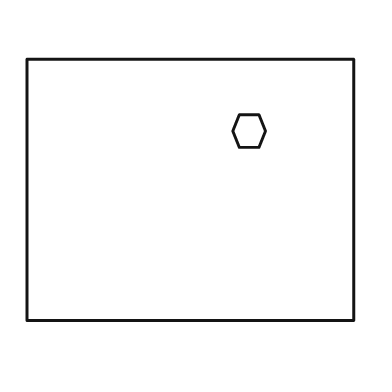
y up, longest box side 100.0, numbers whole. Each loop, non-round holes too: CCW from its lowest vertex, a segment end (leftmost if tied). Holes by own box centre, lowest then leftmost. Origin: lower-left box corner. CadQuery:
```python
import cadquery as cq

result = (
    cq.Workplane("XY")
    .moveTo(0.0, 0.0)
    .lineTo(100.0, 0.0)
    .lineTo(100.0, 80.0)
    .lineTo(0.0, 80.0)
    .close()
    .moveTo(65.0, 53.0)
    .lineTo(71.0, 53.0)
    .lineTo(73.0, 58.0)
    .lineTo(71.0, 63.0)
    .lineTo(65.0, 63.0)
    .lineTo(63.0, 58.0)
    .close()
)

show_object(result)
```